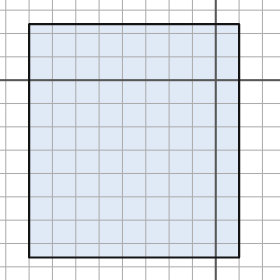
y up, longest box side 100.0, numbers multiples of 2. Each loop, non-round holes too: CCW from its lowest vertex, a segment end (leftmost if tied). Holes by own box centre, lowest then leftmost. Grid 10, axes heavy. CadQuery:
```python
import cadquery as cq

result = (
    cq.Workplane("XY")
    .moveTo(-80.0, -76.0)
    .lineTo(10.0, -76.0)
    .lineTo(10.0, 24.0)
    .lineTo(-80.0, 24.0)
    .close()
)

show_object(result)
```